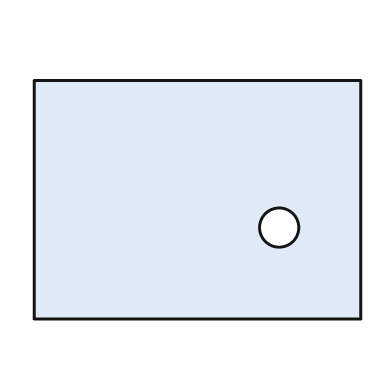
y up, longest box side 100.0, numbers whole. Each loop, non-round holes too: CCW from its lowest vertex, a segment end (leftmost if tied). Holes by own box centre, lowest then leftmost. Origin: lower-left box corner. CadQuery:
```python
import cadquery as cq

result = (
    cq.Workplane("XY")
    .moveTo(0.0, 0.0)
    .lineTo(100.0, 0.0)
    .lineTo(100.0, 73.0)
    .lineTo(0.0, 73.0)
    .close()
    .moveTo(75.0, 28.0)
    .circle(6.0)
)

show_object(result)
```